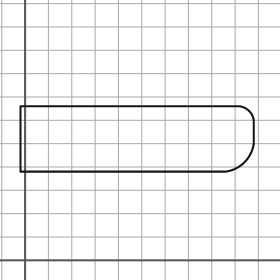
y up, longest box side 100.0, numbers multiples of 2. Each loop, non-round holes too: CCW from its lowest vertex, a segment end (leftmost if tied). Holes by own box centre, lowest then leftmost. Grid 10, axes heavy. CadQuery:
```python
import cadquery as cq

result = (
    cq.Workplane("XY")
    .moveTo(-2.0, 38.0)
    .lineTo(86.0, 38.0)
    .threePointArc((94.0, 42.0), (98.0, 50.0))
    .lineTo(98.0, 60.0)
    .threePointArc((96.0, 64.0), (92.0, 66.0))
    .lineTo(-2.0, 66.0)
    .close()
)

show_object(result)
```